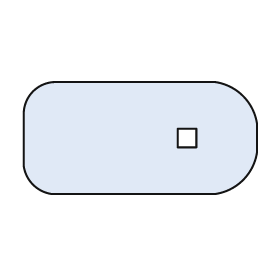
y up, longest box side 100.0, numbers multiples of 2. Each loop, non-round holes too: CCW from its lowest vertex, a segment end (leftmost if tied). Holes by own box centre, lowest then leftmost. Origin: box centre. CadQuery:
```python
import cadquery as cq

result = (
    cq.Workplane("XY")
    .moveTo(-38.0, -24.0)
    .lineTo(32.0, -24.0)
    .threePointArc((44.0, -18.0), (50.0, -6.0))
    .lineTo(50.0, 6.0)
    .threePointArc((44.0, 18.0), (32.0, 24.0))
    .lineTo(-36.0, 24.0)
    .threePointArc((-46.0, 20.0), (-50.0, 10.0))
    .lineTo(-50.0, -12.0)
    .threePointArc((-46.0, -20.0), (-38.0, -24.0))
    .close()
    .moveTo(16.0, -4.0)
    .lineTo(24.0, -4.0)
    .lineTo(24.0, 4.0)
    .lineTo(16.0, 4.0)
    .close()
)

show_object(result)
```